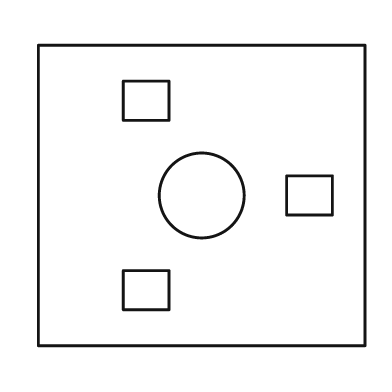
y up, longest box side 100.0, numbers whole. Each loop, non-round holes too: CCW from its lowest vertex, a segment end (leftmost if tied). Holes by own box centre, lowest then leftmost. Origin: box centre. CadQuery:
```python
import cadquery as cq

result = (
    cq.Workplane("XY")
    .moveTo(-50.0, -46.0)
    .lineTo(50.0, -46.0)
    .lineTo(50.0, 46.0)
    .lineTo(-50.0, 46.0)
    .close()
    .moveTo(-24.0, -35.0)
    .lineTo(-10.0, -35.0)
    .lineTo(-10.0, -23.0)
    .lineTo(-24.0, -23.0)
    .close()
    .moveTo(0.0, 0.0)
    .circle(13.0)
    .moveTo(26.0, -6.0)
    .lineTo(40.0, -6.0)
    .lineTo(40.0, 6.0)
    .lineTo(26.0, 6.0)
    .close()
    .moveTo(-24.0, 23.0)
    .lineTo(-10.0, 23.0)
    .lineTo(-10.0, 35.0)
    .lineTo(-24.0, 35.0)
    .close()
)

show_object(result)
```